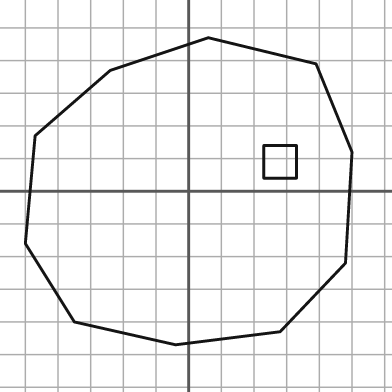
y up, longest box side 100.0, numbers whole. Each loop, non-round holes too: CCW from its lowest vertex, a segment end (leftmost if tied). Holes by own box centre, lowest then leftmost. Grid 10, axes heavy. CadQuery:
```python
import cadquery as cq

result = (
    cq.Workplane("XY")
    .moveTo(-4.0, -47.0)
    .lineTo(28.0, -43.0)
    .lineTo(48.0, -22.0)
    .lineTo(50.0, 12.0)
    .lineTo(39.0, 39.0)
    .lineTo(6.0, 47.0)
    .lineTo(-24.0, 37.0)
    .lineTo(-47.0, 17.0)
    .lineTo(-50.0, -16.0)
    .lineTo(-35.0, -40.0)
    .close()
    .moveTo(23.0, 4.0)
    .lineTo(33.0, 4.0)
    .lineTo(33.0, 14.0)
    .lineTo(23.0, 14.0)
    .close()
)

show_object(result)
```